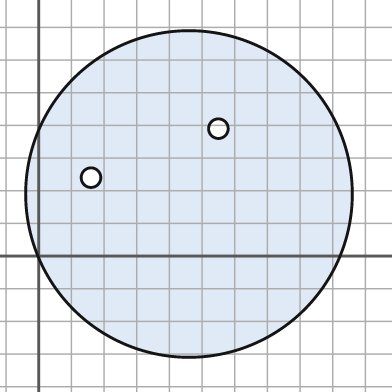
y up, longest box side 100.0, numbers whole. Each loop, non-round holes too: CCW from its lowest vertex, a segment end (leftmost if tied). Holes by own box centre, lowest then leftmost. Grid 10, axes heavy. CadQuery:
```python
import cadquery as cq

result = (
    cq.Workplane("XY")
    .moveTo(46.0, 19.0)
    .circle(50.0)
    .moveTo(16.0, 24.0)
    .circle(3.0)
    .moveTo(55.0, 39.0)
    .circle(3.0)
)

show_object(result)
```